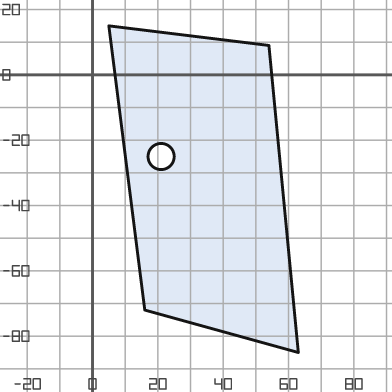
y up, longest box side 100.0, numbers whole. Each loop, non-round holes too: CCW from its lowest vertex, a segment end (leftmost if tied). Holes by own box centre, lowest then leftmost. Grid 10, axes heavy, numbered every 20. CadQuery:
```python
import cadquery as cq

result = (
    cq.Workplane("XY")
    .moveTo(63.0, -85.0)
    .lineTo(54.0, 9.0)
    .lineTo(5.0, 15.0)
    .lineTo(16.0, -72.0)
    .close()
    .moveTo(21.0, -25.0)
    .circle(4.0)
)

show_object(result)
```